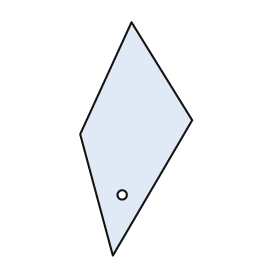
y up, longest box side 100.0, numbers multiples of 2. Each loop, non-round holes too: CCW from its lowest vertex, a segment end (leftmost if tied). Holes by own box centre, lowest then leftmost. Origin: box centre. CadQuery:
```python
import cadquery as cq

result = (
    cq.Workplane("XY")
    .moveTo(-10.0, -50.0)
    .lineTo(24.0, 8.0)
    .lineTo(-2.0, 50.0)
    .lineTo(-24.0, 2.0)
    .close()
    .moveTo(-6.0, -24.0)
    .circle(2.0)
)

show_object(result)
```